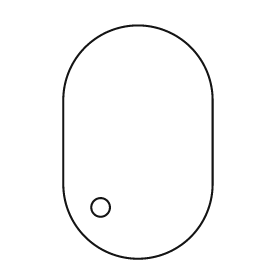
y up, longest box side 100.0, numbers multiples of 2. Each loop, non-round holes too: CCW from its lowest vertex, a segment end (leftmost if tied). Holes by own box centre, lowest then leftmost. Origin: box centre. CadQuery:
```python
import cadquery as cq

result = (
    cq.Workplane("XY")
    .moveTo(-32.0, -18.0)
    .threePointArc((0.0, -50.0), (32.0, -18.0))
    .lineTo(32.0, 18.0)
    .threePointArc((0.0, 50.0), (-32.0, 18.0))
    .close()
    .moveTo(-16.0, -28.0)
    .circle(4.0)
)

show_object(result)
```